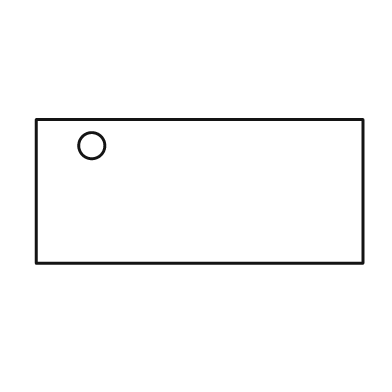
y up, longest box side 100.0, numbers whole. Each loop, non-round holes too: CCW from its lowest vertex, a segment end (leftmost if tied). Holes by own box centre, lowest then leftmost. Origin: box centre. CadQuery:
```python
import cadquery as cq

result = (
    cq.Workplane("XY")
    .moveTo(-50.0, -22.0)
    .lineTo(50.0, -22.0)
    .lineTo(50.0, 22.0)
    .lineTo(-50.0, 22.0)
    .close()
    .moveTo(-33.0, 14.0)
    .circle(4.0)
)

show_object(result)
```